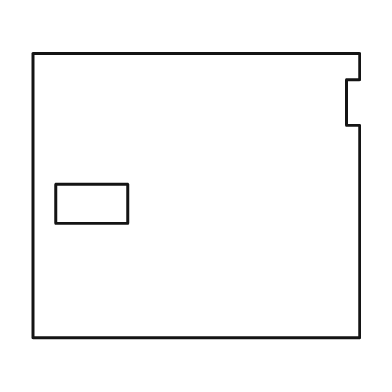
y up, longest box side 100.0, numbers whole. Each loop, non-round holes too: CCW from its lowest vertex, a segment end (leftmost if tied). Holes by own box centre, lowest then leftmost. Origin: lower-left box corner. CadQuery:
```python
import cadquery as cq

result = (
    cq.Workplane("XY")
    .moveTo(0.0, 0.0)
    .lineTo(100.0, 0.0)
    .lineTo(100.0, 65.0)
    .lineTo(96.0, 65.0)
    .lineTo(96.0, 79.0)
    .lineTo(100.0, 79.0)
    .lineTo(100.0, 87.0)
    .lineTo(0.0, 87.0)
    .close()
    .moveTo(7.0, 35.0)
    .lineTo(29.0, 35.0)
    .lineTo(29.0, 47.0)
    .lineTo(7.0, 47.0)
    .close()
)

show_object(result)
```